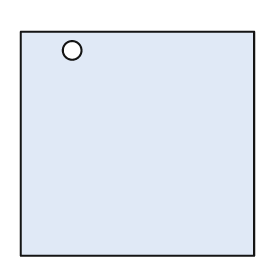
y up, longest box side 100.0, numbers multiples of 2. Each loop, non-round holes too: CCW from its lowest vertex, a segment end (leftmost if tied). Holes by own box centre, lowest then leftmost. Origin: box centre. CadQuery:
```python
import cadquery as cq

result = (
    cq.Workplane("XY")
    .moveTo(-50.0, -48.0)
    .lineTo(50.0, -48.0)
    .lineTo(50.0, 48.0)
    .lineTo(-50.0, 48.0)
    .close()
    .moveTo(-28.0, 40.0)
    .circle(4.0)
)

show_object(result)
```